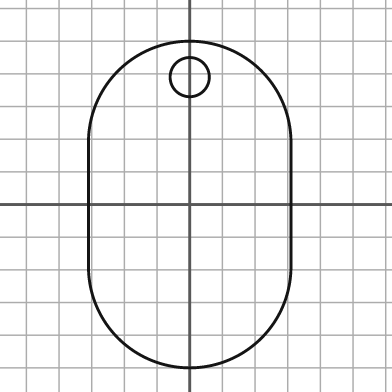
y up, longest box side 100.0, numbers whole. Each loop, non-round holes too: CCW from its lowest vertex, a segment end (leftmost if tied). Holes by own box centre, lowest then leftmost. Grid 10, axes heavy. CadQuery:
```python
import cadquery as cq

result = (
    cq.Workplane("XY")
    .moveTo(-31.0, -19.0)
    .threePointArc((0.0, -50.0), (31.0, -19.0))
    .lineTo(31.0, 19.0)
    .threePointArc((0.0, 50.0), (-31.0, 19.0))
    .close()
    .moveTo(0.0, 39.0)
    .circle(6.0)
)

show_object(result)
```